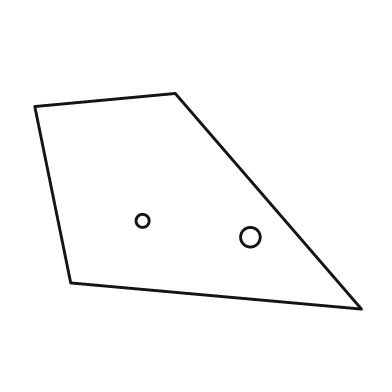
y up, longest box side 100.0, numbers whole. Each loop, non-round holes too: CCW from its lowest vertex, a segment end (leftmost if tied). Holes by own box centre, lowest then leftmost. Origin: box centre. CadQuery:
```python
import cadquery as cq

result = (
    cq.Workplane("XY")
    .moveTo(50.0, -33.0)
    .lineTo(-7.0, 33.0)
    .lineTo(-50.0, 29.0)
    .lineTo(-39.0, -25.0)
    .close()
    .moveTo(16.0, -11.0)
    .circle(3.0)
    .moveTo(-17.0, -6.0)
    .circle(2.0)
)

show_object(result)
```